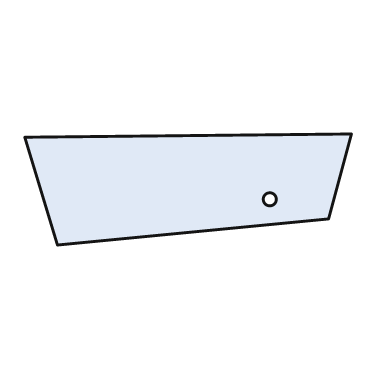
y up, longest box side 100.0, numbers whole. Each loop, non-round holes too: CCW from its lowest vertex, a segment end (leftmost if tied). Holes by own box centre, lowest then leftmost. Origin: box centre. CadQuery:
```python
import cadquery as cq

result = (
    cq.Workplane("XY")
    .moveTo(-40.0, -17.0)
    .lineTo(43.0, -9.0)
    .lineTo(50.0, 17.0)
    .lineTo(-50.0, 16.0)
    .close()
    .moveTo(25.0, -3.0)
    .circle(2.0)
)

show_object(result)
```